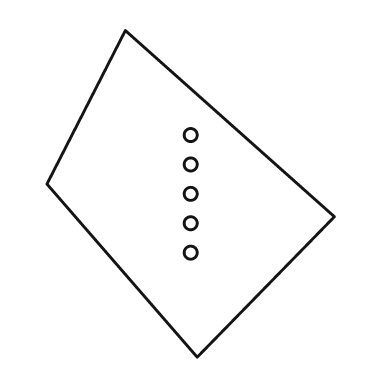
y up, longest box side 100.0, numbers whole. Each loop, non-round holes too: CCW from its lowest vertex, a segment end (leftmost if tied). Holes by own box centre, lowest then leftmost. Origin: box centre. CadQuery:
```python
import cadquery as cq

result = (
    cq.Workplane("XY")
    .moveTo(2.0, -50.0)
    .lineTo(44.0, -7.0)
    .lineTo(-20.0, 50.0)
    .lineTo(-44.0, 3.0)
    .close()
    .moveTo(0.0, -18.0)
    .circle(2.0)
    .moveTo(0.0, -9.0)
    .circle(2.0)
    .moveTo(0.0, 0.0)
    .circle(2.0)
    .moveTo(0.0, 9.0)
    .circle(2.0)
    .moveTo(0.0, 18.0)
    .circle(2.0)
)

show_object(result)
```